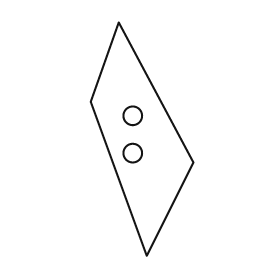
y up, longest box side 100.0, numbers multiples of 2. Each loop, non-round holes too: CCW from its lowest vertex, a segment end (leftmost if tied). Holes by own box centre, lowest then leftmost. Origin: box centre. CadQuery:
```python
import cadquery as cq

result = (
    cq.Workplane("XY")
    .moveTo(2.0, -50.0)
    .lineTo(22.0, -10.0)
    .lineTo(-10.0, 50.0)
    .lineTo(-22.0, 16.0)
    .close()
    .moveTo(-4.0, -6.0)
    .circle(4.0)
    .moveTo(-4.0, 10.0)
    .circle(4.0)
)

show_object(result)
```